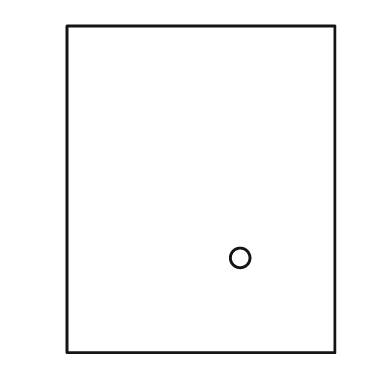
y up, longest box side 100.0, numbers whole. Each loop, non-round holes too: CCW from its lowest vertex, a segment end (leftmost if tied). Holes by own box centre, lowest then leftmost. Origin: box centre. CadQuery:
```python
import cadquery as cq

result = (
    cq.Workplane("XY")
    .moveTo(-41.0, -50.0)
    .lineTo(41.0, -50.0)
    .lineTo(41.0, 50.0)
    .lineTo(-41.0, 50.0)
    .close()
    .moveTo(12.0, -21.0)
    .circle(3.0)
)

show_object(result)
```